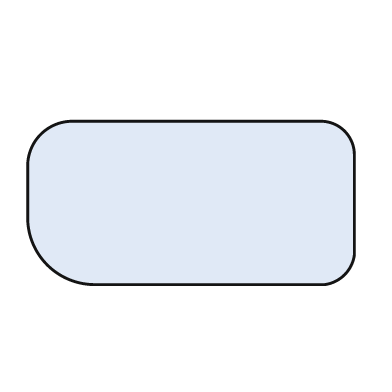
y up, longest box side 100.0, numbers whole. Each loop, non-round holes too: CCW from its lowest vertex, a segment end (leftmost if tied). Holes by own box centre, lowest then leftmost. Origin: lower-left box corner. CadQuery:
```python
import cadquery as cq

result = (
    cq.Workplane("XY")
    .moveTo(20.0, 0.0)
    .lineTo(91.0, 0.0)
    .threePointArc((97.0, 3.0), (100.0, 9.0))
    .lineTo(100.0, 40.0)
    .threePointArc((97.0, 47.0), (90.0, 50.0))
    .lineTo(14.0, 50.0)
    .threePointArc((4.0, 46.0), (0.0, 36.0))
    .lineTo(0.0, 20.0)
    .threePointArc((6.0, 6.0), (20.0, 0.0))
    .close()
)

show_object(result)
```